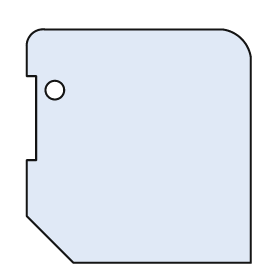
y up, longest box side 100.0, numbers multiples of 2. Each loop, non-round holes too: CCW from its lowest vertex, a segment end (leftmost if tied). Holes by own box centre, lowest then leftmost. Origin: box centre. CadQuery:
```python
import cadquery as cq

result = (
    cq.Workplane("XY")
    .moveTo(-28.0, -50.0)
    .lineTo(48.0, -50.0)
    .lineTo(48.0, 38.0)
    .threePointArc((44.0, 46.0), (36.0, 50.0))
    .lineTo(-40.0, 50.0)
    .threePointArc((-46.0, 48.0), (-48.0, 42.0))
    .lineTo(-48.0, 30.0)
    .lineTo(-44.0, 30.0)
    .lineTo(-44.0, -6.0)
    .lineTo(-48.0, -6.0)
    .lineTo(-48.0, -30.0)
    .close()
    .moveTo(-36.0, 24.0)
    .circle(4.0)
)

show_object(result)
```